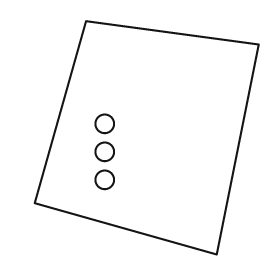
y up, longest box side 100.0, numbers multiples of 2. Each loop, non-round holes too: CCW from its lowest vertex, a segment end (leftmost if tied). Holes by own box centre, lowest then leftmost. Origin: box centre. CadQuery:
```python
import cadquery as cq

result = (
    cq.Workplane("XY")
    .moveTo(30.0, -50.0)
    .lineTo(48.0, 40.0)
    .lineTo(-26.0, 50.0)
    .lineTo(-48.0, -28.0)
    .close()
    .moveTo(-18.0, -18.0)
    .circle(4.0)
    .moveTo(-18.0, -6.0)
    .circle(4.0)
    .moveTo(-18.0, 6.0)
    .circle(4.0)
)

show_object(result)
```